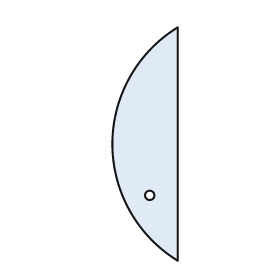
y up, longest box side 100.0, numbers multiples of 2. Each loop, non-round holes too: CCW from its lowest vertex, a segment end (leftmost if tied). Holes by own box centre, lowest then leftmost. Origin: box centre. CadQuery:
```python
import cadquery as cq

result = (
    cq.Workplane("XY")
    .moveTo(14.0, -50.0)
    .lineTo(14.0, 50.0)
    .threePointArc((-14.0, 0.0), (14.0, -50.0))
    .close()
    .moveTo(2.0, -22.0)
    .circle(2.0)
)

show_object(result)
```